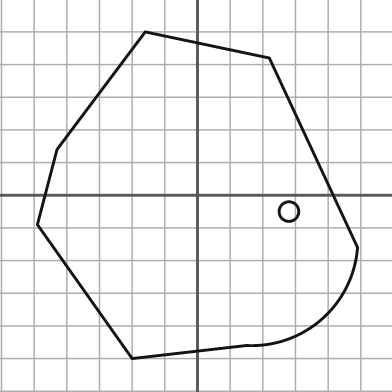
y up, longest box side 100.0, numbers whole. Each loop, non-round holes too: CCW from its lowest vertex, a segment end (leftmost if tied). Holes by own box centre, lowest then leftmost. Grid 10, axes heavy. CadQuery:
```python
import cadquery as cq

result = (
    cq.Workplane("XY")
    .moveTo(-20.0, -50.0)
    .lineTo(15.0, -46.0)
    .threePointArc((38.0, -38.0), (49.0, -16.0))
    .lineTo(22.0, 42.0)
    .lineTo(-16.0, 50.0)
    .lineTo(-43.0, 14.0)
    .lineTo(-49.0, -9.0)
    .close()
    .moveTo(28.0, -5.0)
    .circle(3.0)
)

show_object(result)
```